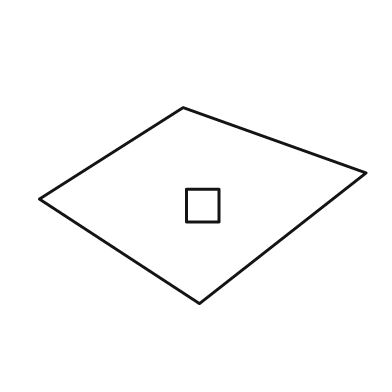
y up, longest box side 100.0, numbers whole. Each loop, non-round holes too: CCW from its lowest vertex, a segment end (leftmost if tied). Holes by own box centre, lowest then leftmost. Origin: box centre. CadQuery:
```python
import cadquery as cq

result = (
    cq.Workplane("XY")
    .moveTo(-1.0, -30.0)
    .lineTo(50.0, 10.0)
    .lineTo(-6.0, 30.0)
    .lineTo(-50.0, 2.0)
    .close()
    .moveTo(-5.0, -5.0)
    .lineTo(5.0, -5.0)
    .lineTo(5.0, 5.0)
    .lineTo(-5.0, 5.0)
    .close()
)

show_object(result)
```